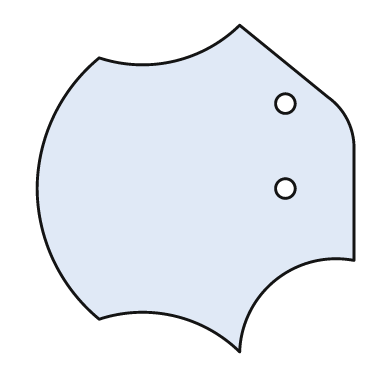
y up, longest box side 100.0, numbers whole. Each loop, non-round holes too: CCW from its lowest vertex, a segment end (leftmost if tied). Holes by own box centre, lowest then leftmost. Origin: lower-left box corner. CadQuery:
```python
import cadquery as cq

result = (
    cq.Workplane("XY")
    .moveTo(62.0, 0.0)
    .threePointArc((73.0, 22.0), (97.0, 28.0))
    .lineTo(97.0, 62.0)
    .threePointArc((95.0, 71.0), (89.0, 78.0))
    .lineTo(62.0, 100.0)
    .threePointArc((42.0, 89.0), (19.0, 90.0))
    .threePointArc((5.0, 72.0), (0.0, 50.0))
    .threePointArc((5.0, 28.0), (19.0, 10.0))
    .threePointArc((42.0, 11.0), (62.0, 0.0))
    .close()
    .moveTo(76.0, 50.0)
    .circle(3.0)
    .moveTo(76.0, 76.0)
    .circle(3.0)
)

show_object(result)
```